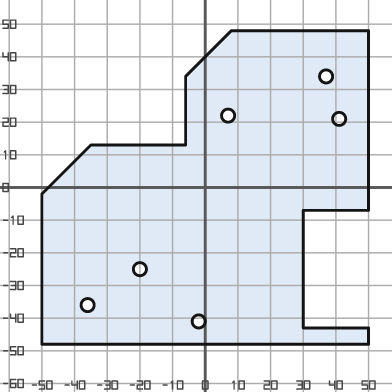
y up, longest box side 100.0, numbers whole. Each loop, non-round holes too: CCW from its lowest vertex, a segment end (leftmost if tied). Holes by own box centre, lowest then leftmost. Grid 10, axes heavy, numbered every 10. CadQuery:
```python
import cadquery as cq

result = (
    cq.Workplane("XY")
    .moveTo(-50.0, -48.0)
    .lineTo(50.0, -48.0)
    .lineTo(50.0, -43.0)
    .lineTo(30.0, -43.0)
    .lineTo(30.0, -7.0)
    .lineTo(50.0, -7.0)
    .lineTo(50.0, 48.0)
    .lineTo(8.0, 48.0)
    .lineTo(-6.0, 34.0)
    .lineTo(-6.0, 13.0)
    .lineTo(-35.0, 13.0)
    .lineTo(-50.0, -2.0)
    .close()
    .moveTo(-2.0, -41.0)
    .circle(2.0)
    .moveTo(-36.0, -36.0)
    .circle(2.0)
    .moveTo(-20.0, -25.0)
    .circle(2.0)
    .moveTo(41.0, 21.0)
    .circle(2.0)
    .moveTo(7.0, 22.0)
    .circle(2.0)
    .moveTo(37.0, 34.0)
    .circle(2.0)
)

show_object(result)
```